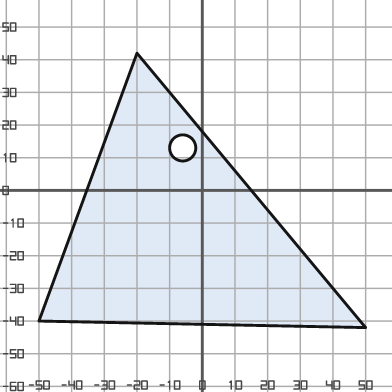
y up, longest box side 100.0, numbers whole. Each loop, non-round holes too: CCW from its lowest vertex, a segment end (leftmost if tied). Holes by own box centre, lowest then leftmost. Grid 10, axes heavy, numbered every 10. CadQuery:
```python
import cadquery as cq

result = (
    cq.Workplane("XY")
    .moveTo(50.0, -42.0)
    .lineTo(-20.0, 42.0)
    .lineTo(-50.0, -40.0)
    .close()
    .moveTo(-6.0, 13.0)
    .circle(4.0)
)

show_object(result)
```